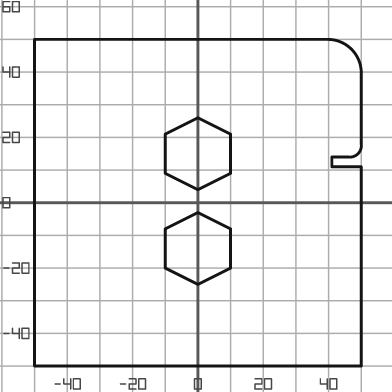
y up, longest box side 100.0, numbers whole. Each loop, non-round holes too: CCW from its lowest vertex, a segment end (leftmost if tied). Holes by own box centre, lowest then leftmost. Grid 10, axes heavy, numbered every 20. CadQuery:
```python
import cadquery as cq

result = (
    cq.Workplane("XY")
    .moveTo(-50.0, -50.0)
    .lineTo(50.0, -50.0)
    .lineTo(50.0, 11.0)
    .lineTo(41.0, 11.0)
    .lineTo(41.0, 14.0)
    .lineTo(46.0, 14.0)
    .threePointArc((49.0, 15.0), (50.0, 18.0))
    .lineTo(50.0, 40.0)
    .threePointArc((47.0, 47.0), (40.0, 50.0))
    .lineTo(-50.0, 50.0)
    .close()
    .moveTo(0.0, -25.0)
    .lineTo(10.0, -20.0)
    .lineTo(10.0, -8.0)
    .lineTo(0.0, -3.0)
    .lineTo(-10.0, -8.0)
    .lineTo(-10.0, -20.0)
    .close()
    .moveTo(0.0, 4.0)
    .lineTo(10.0, 9.0)
    .lineTo(10.0, 21.0)
    .lineTo(0.0, 26.0)
    .lineTo(-10.0, 21.0)
    .lineTo(-10.0, 9.0)
    .close()
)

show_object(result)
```